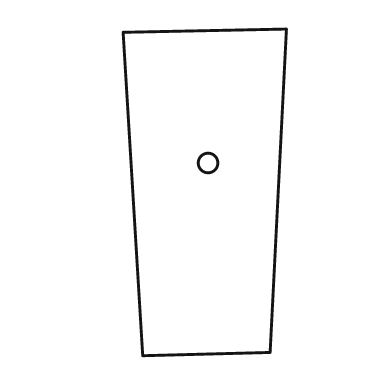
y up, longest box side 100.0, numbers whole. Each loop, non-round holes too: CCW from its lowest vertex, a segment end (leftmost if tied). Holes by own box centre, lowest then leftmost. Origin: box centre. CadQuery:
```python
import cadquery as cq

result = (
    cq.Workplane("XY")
    .moveTo(-19.0, -50.0)
    .lineTo(20.0, -49.0)
    .lineTo(25.0, 50.0)
    .lineTo(-25.0, 49.0)
    .close()
    .moveTo(1.0, 9.0)
    .circle(3.0)
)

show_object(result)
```